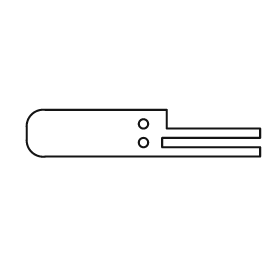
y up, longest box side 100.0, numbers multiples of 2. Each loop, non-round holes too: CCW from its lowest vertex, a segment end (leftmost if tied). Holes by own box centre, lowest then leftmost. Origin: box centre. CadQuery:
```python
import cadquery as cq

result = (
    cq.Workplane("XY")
    .moveTo(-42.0, -10.0)
    .lineTo(50.0, -10.0)
    .lineTo(50.0, -6.0)
    .lineTo(8.0, -6.0)
    .lineTo(8.0, -2.0)
    .lineTo(50.0, -2.0)
    .lineTo(50.0, 2.0)
    .lineTo(10.0, 2.0)
    .lineTo(10.0, 10.0)
    .lineTo(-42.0, 10.0)
    .threePointArc((-48.0, 8.0), (-50.0, 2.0))
    .lineTo(-50.0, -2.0)
    .threePointArc((-48.0, -8.0), (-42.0, -10.0))
    .close()
    .moveTo(0.0, -4.0)
    .circle(2.0)
    .moveTo(0.0, 4.0)
    .circle(2.0)
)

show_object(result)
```